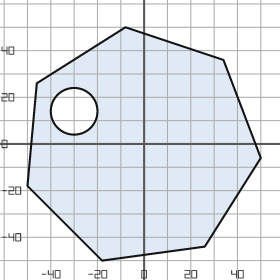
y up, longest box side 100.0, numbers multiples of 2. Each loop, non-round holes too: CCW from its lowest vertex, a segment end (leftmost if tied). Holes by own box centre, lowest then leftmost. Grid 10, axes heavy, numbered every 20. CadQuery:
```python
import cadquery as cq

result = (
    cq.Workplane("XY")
    .moveTo(-18.0, -50.0)
    .lineTo(26.0, -44.0)
    .lineTo(50.0, -6.0)
    .lineTo(34.0, 36.0)
    .lineTo(-8.0, 50.0)
    .lineTo(-46.0, 26.0)
    .lineTo(-50.0, -18.0)
    .close()
    .moveTo(-30.0, 14.0)
    .circle(10.0)
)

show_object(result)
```